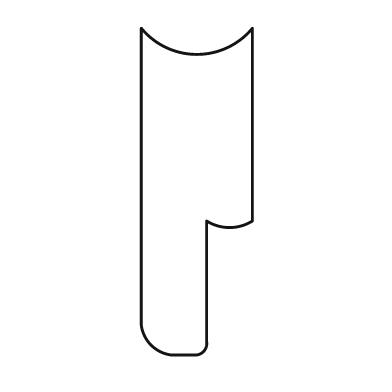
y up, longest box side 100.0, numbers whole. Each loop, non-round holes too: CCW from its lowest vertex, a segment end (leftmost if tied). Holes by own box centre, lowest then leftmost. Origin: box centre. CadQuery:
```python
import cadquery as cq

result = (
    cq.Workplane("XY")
    .moveTo(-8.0, -50.0)
    .lineTo(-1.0, -50.0)
    .threePointArc((2.0, -49.0), (3.0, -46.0))
    .lineTo(3.0, -9.0)
    .threePointArc((10.0, -11.0), (17.0, -9.0))
    .lineTo(17.0, 50.0)
    .threePointArc((0.0, 42.0), (-17.0, 50.0))
    .lineTo(-17.0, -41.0)
    .threePointArc((-14.0, -47.0), (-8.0, -50.0))
    .close()
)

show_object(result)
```